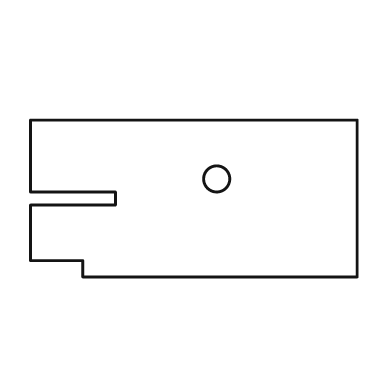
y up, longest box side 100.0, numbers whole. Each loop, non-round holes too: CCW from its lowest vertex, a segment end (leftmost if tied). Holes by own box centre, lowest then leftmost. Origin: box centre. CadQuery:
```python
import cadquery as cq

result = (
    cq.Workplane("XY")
    .moveTo(-34.0, -24.0)
    .lineTo(50.0, -24.0)
    .lineTo(50.0, 24.0)
    .lineTo(-50.0, 24.0)
    .lineTo(-50.0, 2.0)
    .lineTo(-24.0, 2.0)
    .lineTo(-24.0, -2.0)
    .lineTo(-50.0, -2.0)
    .lineTo(-50.0, -19.0)
    .lineTo(-34.0, -19.0)
    .close()
    .moveTo(7.0, 6.0)
    .circle(4.0)
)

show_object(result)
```